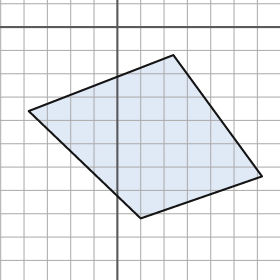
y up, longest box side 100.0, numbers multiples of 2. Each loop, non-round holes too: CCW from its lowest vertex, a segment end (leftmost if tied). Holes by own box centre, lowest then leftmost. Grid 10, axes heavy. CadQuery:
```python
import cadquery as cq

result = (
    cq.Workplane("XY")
    .moveTo(10.0, -82.0)
    .lineTo(62.0, -64.0)
    .lineTo(24.0, -12.0)
    .lineTo(-38.0, -36.0)
    .close()
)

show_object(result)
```